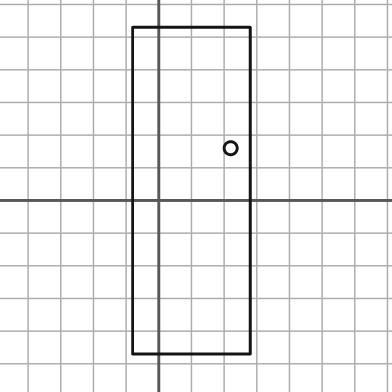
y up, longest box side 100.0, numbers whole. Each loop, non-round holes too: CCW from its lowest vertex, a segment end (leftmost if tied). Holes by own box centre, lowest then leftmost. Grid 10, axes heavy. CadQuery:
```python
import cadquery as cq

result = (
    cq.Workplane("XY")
    .moveTo(-8.0, -47.0)
    .lineTo(28.0, -47.0)
    .lineTo(28.0, 53.0)
    .lineTo(-8.0, 53.0)
    .close()
    .moveTo(22.0, 16.0)
    .circle(2.0)
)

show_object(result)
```